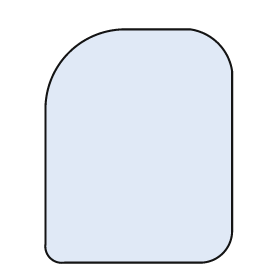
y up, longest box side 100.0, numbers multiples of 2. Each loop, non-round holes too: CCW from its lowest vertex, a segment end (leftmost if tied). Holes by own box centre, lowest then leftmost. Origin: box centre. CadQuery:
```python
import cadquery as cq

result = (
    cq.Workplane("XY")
    .moveTo(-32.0, -50.0)
    .lineTo(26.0, -50.0)
    .threePointArc((36.0, -46.0), (40.0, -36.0))
    .lineTo(40.0, 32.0)
    .threePointArc((34.0, 44.0), (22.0, 50.0))
    .lineTo(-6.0, 50.0)
    .threePointArc((-30.0, 40.0), (-40.0, 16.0))
    .lineTo(-40.0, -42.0)
    .threePointArc((-38.0, -48.0), (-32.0, -50.0))
    .close()
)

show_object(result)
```